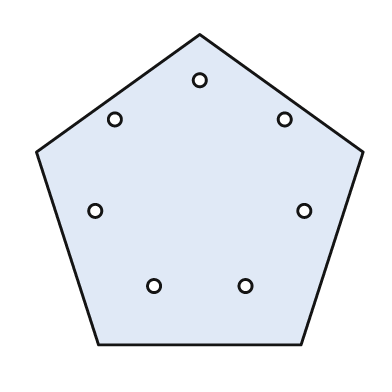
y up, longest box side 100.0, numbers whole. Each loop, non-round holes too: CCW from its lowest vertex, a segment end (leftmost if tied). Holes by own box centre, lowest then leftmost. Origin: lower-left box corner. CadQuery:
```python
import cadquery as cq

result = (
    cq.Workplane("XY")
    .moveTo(19.0, 0.0)
    .lineTo(81.0, 0.0)
    .lineTo(100.0, 59.0)
    .lineTo(50.0, 95.0)
    .lineTo(0.0, 59.0)
    .close()
    .moveTo(36.0, 18.0)
    .circle(2.0)
    .moveTo(64.0, 18.0)
    .circle(2.0)
    .moveTo(18.0, 41.0)
    .circle(2.0)
    .moveTo(82.0, 41.0)
    .circle(2.0)
    .moveTo(24.0, 69.0)
    .circle(2.0)
    .moveTo(76.0, 69.0)
    .circle(2.0)
    .moveTo(50.0, 81.0)
    .circle(2.0)
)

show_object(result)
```